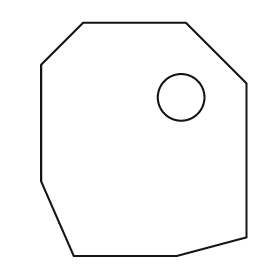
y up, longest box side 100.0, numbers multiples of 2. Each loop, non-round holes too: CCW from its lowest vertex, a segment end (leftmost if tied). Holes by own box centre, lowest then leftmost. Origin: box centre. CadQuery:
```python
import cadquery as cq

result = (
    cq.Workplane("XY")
    .moveTo(-30.0, -50.0)
    .lineTo(14.0, -50.0)
    .lineTo(44.0, -42.0)
    .lineTo(44.0, 24.0)
    .lineTo(18.0, 50.0)
    .lineTo(-26.0, 50.0)
    .lineTo(-44.0, 32.0)
    .lineTo(-44.0, -18.0)
    .close()
    .moveTo(16.0, 18.0)
    .circle(10.0)
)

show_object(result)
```